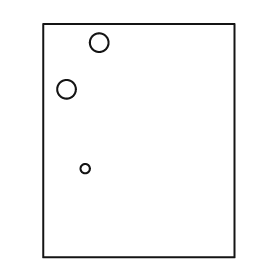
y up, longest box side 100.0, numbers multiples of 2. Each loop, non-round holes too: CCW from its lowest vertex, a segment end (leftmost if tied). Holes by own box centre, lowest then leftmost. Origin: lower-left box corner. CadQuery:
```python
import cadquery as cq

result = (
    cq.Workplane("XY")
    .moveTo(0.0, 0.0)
    .lineTo(82.0, 0.0)
    .lineTo(82.0, 100.0)
    .lineTo(0.0, 100.0)
    .close()
    .moveTo(18.0, 38.0)
    .circle(2.0)
    .moveTo(10.0, 72.0)
    .circle(4.0)
    .moveTo(24.0, 92.0)
    .circle(4.0)
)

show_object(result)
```